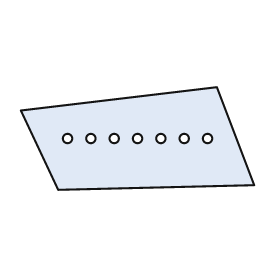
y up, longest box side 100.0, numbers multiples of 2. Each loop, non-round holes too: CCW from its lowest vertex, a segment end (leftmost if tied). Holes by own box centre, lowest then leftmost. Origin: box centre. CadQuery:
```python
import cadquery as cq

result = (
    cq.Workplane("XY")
    .moveTo(-34.0, -22.0)
    .lineTo(50.0, -20.0)
    .lineTo(34.0, 22.0)
    .lineTo(-50.0, 12.0)
    .close()
    .moveTo(-30.0, 0.0)
    .circle(2.0)
    .moveTo(-20.0, 0.0)
    .circle(2.0)
    .moveTo(-10.0, 0.0)
    .circle(2.0)
    .moveTo(0.0, 0.0)
    .circle(2.0)
    .moveTo(10.0, 0.0)
    .circle(2.0)
    .moveTo(20.0, 0.0)
    .circle(2.0)
    .moveTo(30.0, 0.0)
    .circle(2.0)
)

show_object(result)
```